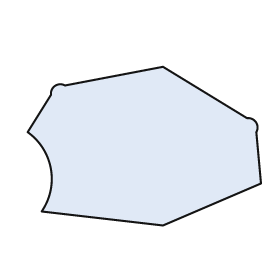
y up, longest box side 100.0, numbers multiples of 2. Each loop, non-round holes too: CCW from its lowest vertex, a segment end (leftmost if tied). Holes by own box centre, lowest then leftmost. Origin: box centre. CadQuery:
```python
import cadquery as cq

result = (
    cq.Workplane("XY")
    .moveTo(8.0, -34.0)
    .lineTo(50.0, -16.0)
    .lineTo(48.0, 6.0)
    .threePointArc((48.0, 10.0), (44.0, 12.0))
    .lineTo(8.0, 34.0)
    .lineTo(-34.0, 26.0)
    .threePointArc((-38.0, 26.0), (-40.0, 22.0))
    .lineTo(-50.0, 6.0)
    .threePointArc((-40.0, -10.0), (-44.0, -28.0))
    .close()
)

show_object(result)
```